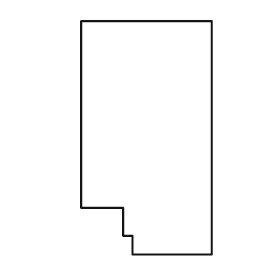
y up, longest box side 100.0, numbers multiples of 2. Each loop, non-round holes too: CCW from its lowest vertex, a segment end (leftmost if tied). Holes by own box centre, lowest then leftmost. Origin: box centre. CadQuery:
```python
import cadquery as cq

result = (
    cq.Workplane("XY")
    .moveTo(-6.0, -50.0)
    .lineTo(28.0, -50.0)
    .lineTo(28.0, 50.0)
    .lineTo(-28.0, 50.0)
    .lineTo(-28.0, -30.0)
    .lineTo(-10.0, -30.0)
    .lineTo(-10.0, -42.0)
    .lineTo(-6.0, -42.0)
    .close()
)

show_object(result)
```